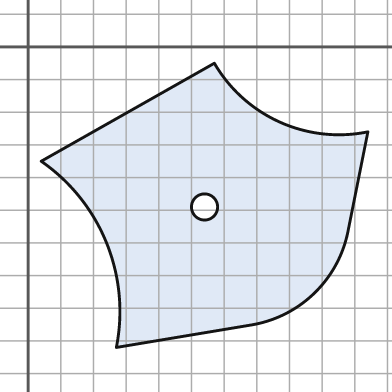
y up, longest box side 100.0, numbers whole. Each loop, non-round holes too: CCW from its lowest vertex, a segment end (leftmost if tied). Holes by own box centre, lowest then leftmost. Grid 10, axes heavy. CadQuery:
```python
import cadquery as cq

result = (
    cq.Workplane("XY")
    .moveTo(27.0, -92.0)
    .lineTo(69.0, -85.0)
    .threePointArc((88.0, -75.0), (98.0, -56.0))
    .lineTo(104.0, -26.0)
    .threePointArc((77.0, -23.0), (57.0, -5.0))
    .lineTo(4.0, -35.0)
    .threePointArc((24.0, -60.0), (27.0, -92.0))
    .close()
    .moveTo(54.0, -49.0)
    .circle(4.0)
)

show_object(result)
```